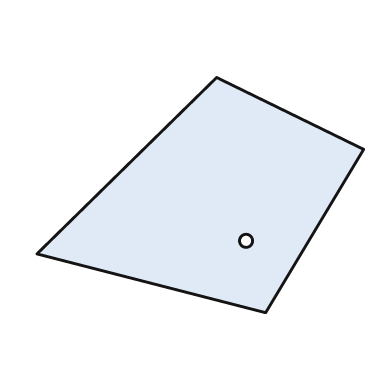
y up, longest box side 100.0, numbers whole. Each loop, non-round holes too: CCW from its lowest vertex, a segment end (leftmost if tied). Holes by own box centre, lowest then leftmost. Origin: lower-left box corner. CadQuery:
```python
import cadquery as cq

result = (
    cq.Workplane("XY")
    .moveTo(70.0, 0.0)
    .lineTo(100.0, 50.0)
    .lineTo(55.0, 72.0)
    .lineTo(0.0, 18.0)
    .close()
    .moveTo(64.0, 22.0)
    .circle(2.0)
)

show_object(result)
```